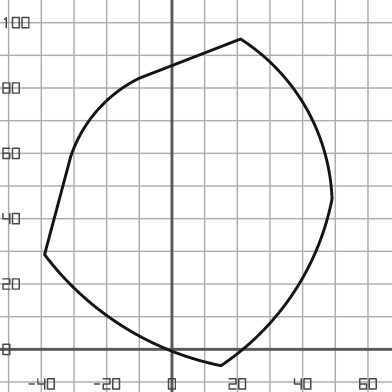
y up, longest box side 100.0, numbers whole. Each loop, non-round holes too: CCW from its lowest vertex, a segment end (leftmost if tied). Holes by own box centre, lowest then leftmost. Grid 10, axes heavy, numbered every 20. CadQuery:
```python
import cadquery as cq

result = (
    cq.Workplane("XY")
    .moveTo(15.0, -5.0)
    .threePointArc((37.0, 17.0), (49.0, 46.0))
    .threePointArc((41.0, 74.0), (21.0, 95.0))
    .lineTo(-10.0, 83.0)
    .threePointArc((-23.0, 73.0), (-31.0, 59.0))
    .lineTo(-39.0, 29.0)
    .threePointArc((-15.0, 7.0), (15.0, -5.0))
    .close()
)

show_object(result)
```